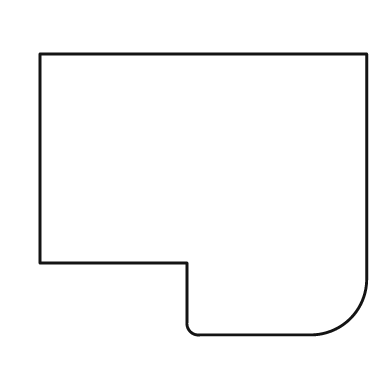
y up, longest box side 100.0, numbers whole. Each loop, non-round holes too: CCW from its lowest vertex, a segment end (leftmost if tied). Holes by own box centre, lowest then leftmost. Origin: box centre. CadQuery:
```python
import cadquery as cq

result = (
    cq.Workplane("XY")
    .moveTo(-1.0, -43.0)
    .lineTo(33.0, -43.0)
    .threePointArc((45.0, -38.0), (50.0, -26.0))
    .lineTo(50.0, 43.0)
    .lineTo(-50.0, 43.0)
    .lineTo(-50.0, -21.0)
    .lineTo(-5.0, -21.0)
    .lineTo(-5.0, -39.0)
    .threePointArc((-4.0, -42.0), (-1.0, -43.0))
    .close()
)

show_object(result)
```